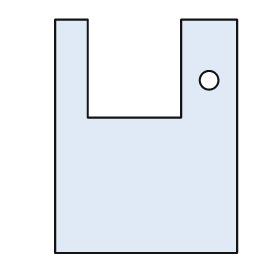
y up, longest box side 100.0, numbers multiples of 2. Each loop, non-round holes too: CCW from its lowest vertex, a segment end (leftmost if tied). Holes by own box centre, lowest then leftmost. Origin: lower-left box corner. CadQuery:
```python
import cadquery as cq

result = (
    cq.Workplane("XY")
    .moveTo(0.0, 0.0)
    .lineTo(78.0, 0.0)
    .lineTo(78.0, 100.0)
    .lineTo(54.0, 100.0)
    .lineTo(54.0, 58.0)
    .lineTo(14.0, 58.0)
    .lineTo(14.0, 100.0)
    .lineTo(0.0, 100.0)
    .close()
    .moveTo(66.0, 74.0)
    .circle(4.0)
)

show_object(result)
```